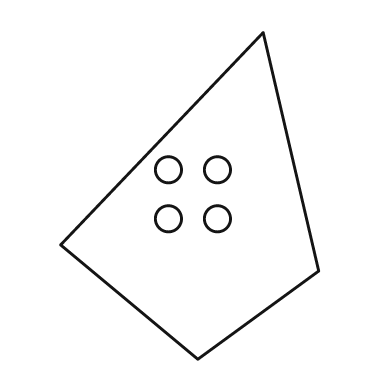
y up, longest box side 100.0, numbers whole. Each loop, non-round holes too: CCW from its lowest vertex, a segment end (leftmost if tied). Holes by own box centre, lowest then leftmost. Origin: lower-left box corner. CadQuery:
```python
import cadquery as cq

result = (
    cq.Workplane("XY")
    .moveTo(42.0, 0.0)
    .lineTo(79.0, 27.0)
    .lineTo(62.0, 100.0)
    .lineTo(0.0, 35.0)
    .close()
    .moveTo(33.0, 43.0)
    .circle(4.0)
    .moveTo(48.0, 43.0)
    .circle(4.0)
    .moveTo(33.0, 58.0)
    .circle(4.0)
    .moveTo(48.0, 58.0)
    .circle(4.0)
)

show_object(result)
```